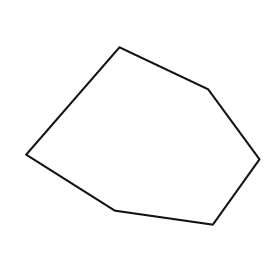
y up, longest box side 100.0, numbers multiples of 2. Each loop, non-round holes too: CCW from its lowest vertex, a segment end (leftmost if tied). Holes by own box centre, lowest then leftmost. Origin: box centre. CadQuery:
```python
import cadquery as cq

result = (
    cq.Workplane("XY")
    .moveTo(30.0, -38.0)
    .lineTo(50.0, -10.0)
    .lineTo(28.0, 20.0)
    .lineTo(-10.0, 38.0)
    .lineTo(-50.0, -8.0)
    .lineTo(-12.0, -32.0)
    .close()
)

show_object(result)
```